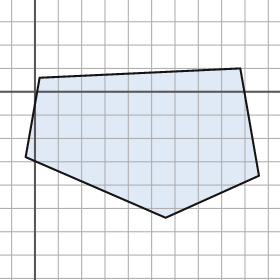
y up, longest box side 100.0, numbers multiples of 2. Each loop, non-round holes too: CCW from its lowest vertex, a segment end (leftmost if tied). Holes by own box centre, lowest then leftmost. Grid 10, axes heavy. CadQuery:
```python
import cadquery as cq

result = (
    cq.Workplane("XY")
    .moveTo(56.0, -54.0)
    .lineTo(96.0, -36.0)
    .lineTo(88.0, 10.0)
    .lineTo(2.0, 6.0)
    .lineTo(-4.0, -28.0)
    .close()
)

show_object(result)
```